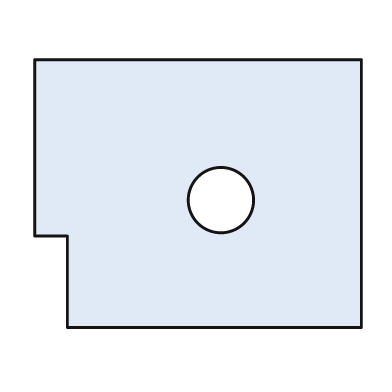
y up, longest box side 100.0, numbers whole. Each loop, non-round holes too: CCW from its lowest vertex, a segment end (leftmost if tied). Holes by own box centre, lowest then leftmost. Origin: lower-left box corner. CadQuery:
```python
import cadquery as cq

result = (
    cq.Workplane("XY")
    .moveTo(10.0, 0.0)
    .lineTo(100.0, 0.0)
    .lineTo(100.0, 82.0)
    .lineTo(0.0, 82.0)
    .lineTo(0.0, 28.0)
    .lineTo(10.0, 28.0)
    .close()
    .moveTo(57.0, 39.0)
    .circle(10.0)
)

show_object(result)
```